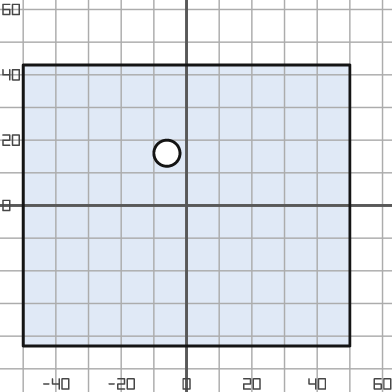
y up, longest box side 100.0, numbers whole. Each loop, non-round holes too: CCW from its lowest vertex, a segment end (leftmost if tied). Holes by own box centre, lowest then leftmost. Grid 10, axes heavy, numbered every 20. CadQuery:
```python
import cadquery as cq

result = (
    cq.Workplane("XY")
    .moveTo(-50.0, -43.0)
    .lineTo(50.0, -43.0)
    .lineTo(50.0, 43.0)
    .lineTo(-50.0, 43.0)
    .close()
    .moveTo(-6.0, 16.0)
    .circle(4.0)
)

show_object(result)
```